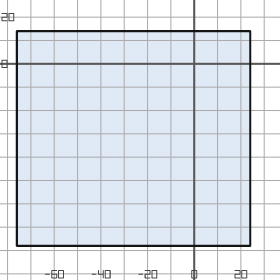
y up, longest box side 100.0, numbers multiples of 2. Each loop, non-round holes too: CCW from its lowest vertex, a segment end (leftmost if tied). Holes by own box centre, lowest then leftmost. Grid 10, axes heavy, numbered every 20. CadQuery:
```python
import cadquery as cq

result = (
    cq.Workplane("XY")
    .moveTo(-76.0, -78.0)
    .lineTo(24.0, -78.0)
    .lineTo(24.0, 14.0)
    .lineTo(-76.0, 14.0)
    .close()
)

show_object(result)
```